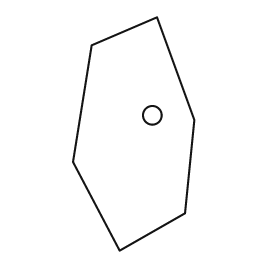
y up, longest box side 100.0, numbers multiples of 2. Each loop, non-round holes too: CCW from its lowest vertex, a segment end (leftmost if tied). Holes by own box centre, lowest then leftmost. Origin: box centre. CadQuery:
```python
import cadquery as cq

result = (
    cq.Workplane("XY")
    .moveTo(-6.0, -50.0)
    .lineTo(22.0, -34.0)
    .lineTo(26.0, 6.0)
    .lineTo(10.0, 50.0)
    .lineTo(-18.0, 38.0)
    .lineTo(-26.0, -12.0)
    .close()
    .moveTo(8.0, 8.0)
    .circle(4.0)
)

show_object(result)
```